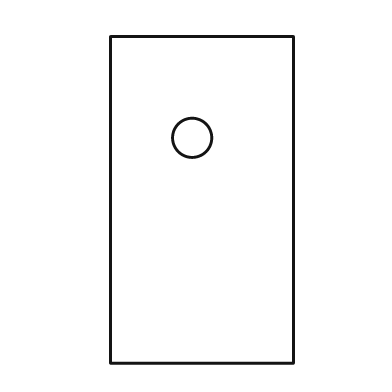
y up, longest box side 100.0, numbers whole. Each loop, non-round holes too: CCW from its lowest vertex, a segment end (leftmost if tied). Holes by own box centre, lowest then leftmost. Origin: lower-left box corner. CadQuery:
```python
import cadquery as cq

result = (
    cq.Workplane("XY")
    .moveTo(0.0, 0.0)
    .lineTo(56.0, 0.0)
    .lineTo(56.0, 100.0)
    .lineTo(0.0, 100.0)
    .close()
    .moveTo(25.0, 69.0)
    .circle(6.0)
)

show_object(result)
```